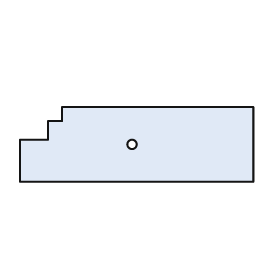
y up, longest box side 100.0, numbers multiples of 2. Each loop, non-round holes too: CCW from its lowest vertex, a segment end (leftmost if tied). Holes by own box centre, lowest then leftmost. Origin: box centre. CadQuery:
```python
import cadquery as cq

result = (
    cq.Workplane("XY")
    .moveTo(-50.0, -16.0)
    .lineTo(50.0, -16.0)
    .lineTo(50.0, 16.0)
    .lineTo(-32.0, 16.0)
    .lineTo(-32.0, 10.0)
    .lineTo(-38.0, 10.0)
    .lineTo(-38.0, 2.0)
    .lineTo(-50.0, 2.0)
    .close()
    .moveTo(-2.0, 0.0)
    .circle(2.0)
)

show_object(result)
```